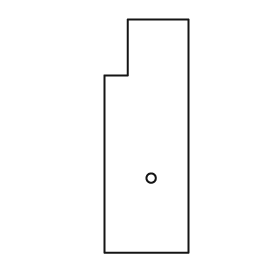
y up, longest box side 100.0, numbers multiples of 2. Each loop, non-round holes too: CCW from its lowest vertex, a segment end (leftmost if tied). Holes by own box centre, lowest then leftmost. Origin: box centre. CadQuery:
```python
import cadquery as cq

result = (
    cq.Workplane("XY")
    .moveTo(-18.0, -50.0)
    .lineTo(18.0, -50.0)
    .lineTo(18.0, 50.0)
    .lineTo(-8.0, 50.0)
    .lineTo(-8.0, 26.0)
    .lineTo(-18.0, 26.0)
    .close()
    .moveTo(2.0, -18.0)
    .circle(2.0)
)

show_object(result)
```